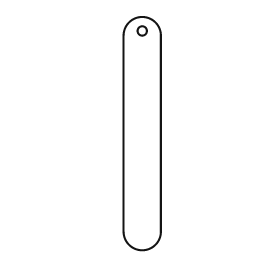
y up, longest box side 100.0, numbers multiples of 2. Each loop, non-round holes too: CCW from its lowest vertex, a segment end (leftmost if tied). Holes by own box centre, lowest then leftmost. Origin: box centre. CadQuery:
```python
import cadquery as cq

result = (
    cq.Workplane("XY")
    .moveTo(-8.0, -42.0)
    .threePointArc((0.0, -50.0), (8.0, -42.0))
    .lineTo(8.0, 42.0)
    .threePointArc((0.0, 50.0), (-8.0, 42.0))
    .close()
    .moveTo(0.0, 44.0)
    .circle(2.0)
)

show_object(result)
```